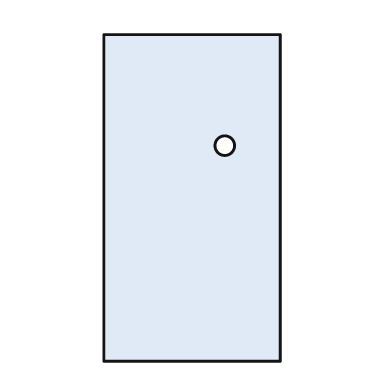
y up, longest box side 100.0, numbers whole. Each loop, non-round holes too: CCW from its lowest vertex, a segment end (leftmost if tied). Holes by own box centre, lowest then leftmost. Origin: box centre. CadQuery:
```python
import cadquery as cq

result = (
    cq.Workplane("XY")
    .moveTo(-27.0, -50.0)
    .lineTo(27.0, -50.0)
    .lineTo(27.0, 50.0)
    .lineTo(-27.0, 50.0)
    .close()
    .moveTo(10.0, 16.0)
    .circle(3.0)
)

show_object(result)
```